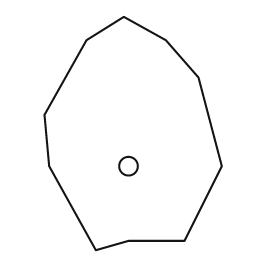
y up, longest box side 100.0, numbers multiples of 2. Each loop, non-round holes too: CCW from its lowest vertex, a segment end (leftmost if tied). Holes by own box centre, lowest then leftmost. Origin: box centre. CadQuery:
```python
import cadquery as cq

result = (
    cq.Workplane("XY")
    .moveTo(-16.0, -50.0)
    .lineTo(-2.0, -46.0)
    .lineTo(22.0, -46.0)
    .lineTo(38.0, -14.0)
    .lineTo(28.0, 24.0)
    .lineTo(14.0, 40.0)
    .lineTo(-4.0, 50.0)
    .lineTo(-20.0, 40.0)
    .lineTo(-38.0, 8.0)
    .lineTo(-36.0, -14.0)
    .close()
    .moveTo(-2.0, -14.0)
    .circle(4.0)
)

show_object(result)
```